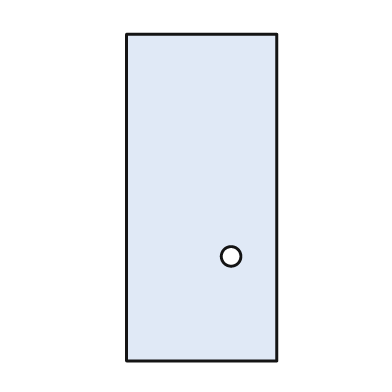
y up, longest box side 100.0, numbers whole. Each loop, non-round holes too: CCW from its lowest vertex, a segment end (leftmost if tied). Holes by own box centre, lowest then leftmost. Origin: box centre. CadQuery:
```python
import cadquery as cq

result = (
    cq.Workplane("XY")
    .moveTo(-23.0, -50.0)
    .lineTo(23.0, -50.0)
    .lineTo(23.0, 50.0)
    .lineTo(-23.0, 50.0)
    .close()
    .moveTo(9.0, -18.0)
    .circle(3.0)
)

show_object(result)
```